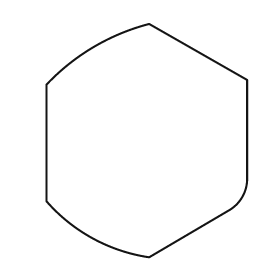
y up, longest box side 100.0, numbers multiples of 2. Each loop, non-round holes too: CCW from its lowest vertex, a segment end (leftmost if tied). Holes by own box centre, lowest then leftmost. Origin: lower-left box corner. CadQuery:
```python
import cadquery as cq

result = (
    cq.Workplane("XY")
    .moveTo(44.0, 0.0)
    .lineTo(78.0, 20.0)
    .threePointArc((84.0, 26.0), (86.0, 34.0))
    .lineTo(86.0, 76.0)
    .lineTo(44.0, 100.0)
    .threePointArc((20.0, 90.0), (0.0, 74.0))
    .lineTo(0.0, 24.0)
    .threePointArc((20.0, 8.0), (44.0, 0.0))
    .close()
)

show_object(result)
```